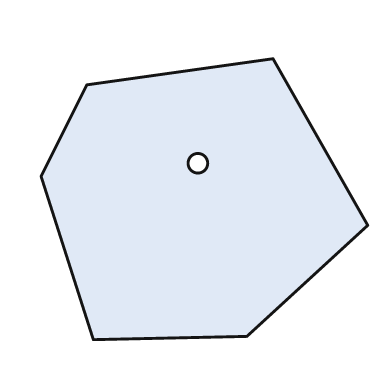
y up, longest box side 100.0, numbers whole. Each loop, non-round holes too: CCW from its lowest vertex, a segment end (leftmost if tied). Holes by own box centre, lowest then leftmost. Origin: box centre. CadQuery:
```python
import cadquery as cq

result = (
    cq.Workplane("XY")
    .moveTo(-34.0, -43.0)
    .lineTo(13.0, -42.0)
    .lineTo(50.0, -8.0)
    .lineTo(21.0, 43.0)
    .lineTo(-36.0, 35.0)
    .lineTo(-50.0, 7.0)
    .close()
    .moveTo(-2.0, 11.0)
    .circle(3.0)
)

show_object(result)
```